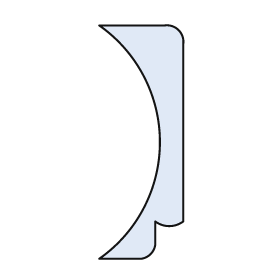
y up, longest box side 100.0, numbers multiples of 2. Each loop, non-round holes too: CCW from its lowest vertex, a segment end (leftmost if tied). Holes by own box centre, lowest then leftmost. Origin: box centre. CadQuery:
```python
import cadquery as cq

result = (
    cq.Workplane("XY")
    .moveTo(-18.0, -50.0)
    .lineTo(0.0, -50.0)
    .threePointArc((4.0, -48.0), (6.0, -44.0))
    .lineTo(6.0, -34.0)
    .threePointArc((12.0, -36.0), (18.0, -34.0))
    .lineTo(18.0, 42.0)
    .threePointArc((16.0, 48.0), (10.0, 50.0))
    .lineTo(-18.0, 50.0)
    .threePointArc((8.0, 0.0), (-18.0, -50.0))
    .close()
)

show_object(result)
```